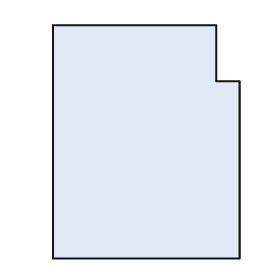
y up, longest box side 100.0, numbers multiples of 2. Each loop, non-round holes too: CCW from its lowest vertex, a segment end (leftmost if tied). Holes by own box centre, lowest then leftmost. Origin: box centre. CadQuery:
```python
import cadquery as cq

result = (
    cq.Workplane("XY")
    .moveTo(-40.0, -50.0)
    .lineTo(40.0, -50.0)
    .lineTo(40.0, 26.0)
    .lineTo(30.0, 26.0)
    .lineTo(30.0, 50.0)
    .lineTo(-40.0, 50.0)
    .close()
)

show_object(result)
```